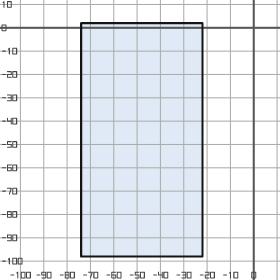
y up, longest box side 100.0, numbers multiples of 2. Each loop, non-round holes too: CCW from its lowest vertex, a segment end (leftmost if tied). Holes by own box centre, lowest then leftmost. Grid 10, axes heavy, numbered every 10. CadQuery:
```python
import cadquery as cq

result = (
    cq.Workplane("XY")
    .moveTo(-74.0, -98.0)
    .lineTo(-22.0, -98.0)
    .lineTo(-22.0, 2.0)
    .lineTo(-74.0, 2.0)
    .close()
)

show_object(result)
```